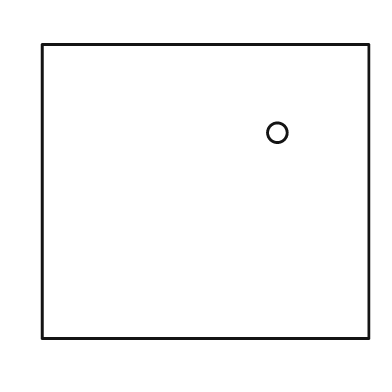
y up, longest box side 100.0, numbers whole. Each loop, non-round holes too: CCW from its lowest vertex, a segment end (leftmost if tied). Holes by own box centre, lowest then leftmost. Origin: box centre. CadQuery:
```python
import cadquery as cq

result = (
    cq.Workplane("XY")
    .moveTo(-50.0, -45.0)
    .lineTo(50.0, -45.0)
    .lineTo(50.0, 45.0)
    .lineTo(-50.0, 45.0)
    .close()
    .moveTo(22.0, 18.0)
    .circle(3.0)
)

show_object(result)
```